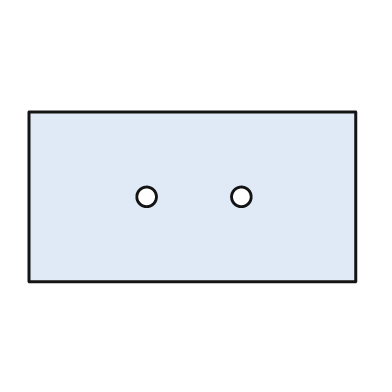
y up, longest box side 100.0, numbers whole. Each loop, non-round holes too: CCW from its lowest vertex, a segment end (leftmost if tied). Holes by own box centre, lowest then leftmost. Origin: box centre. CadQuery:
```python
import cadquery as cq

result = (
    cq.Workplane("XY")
    .moveTo(-50.0, -26.0)
    .lineTo(50.0, -26.0)
    .lineTo(50.0, 26.0)
    .lineTo(-50.0, 26.0)
    .close()
    .moveTo(-14.0, 0.0)
    .circle(3.0)
    .moveTo(15.0, 0.0)
    .circle(3.0)
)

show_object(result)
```